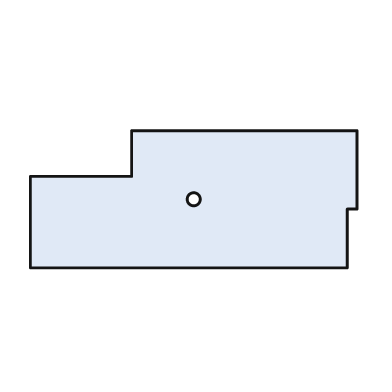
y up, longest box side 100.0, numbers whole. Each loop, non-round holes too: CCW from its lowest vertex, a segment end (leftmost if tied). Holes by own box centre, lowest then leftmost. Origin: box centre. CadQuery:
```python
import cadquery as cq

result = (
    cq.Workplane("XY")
    .moveTo(-50.0, -21.0)
    .lineTo(47.0, -21.0)
    .lineTo(47.0, -3.0)
    .lineTo(50.0, -3.0)
    .lineTo(50.0, 21.0)
    .lineTo(-19.0, 21.0)
    .lineTo(-19.0, 7.0)
    .lineTo(-50.0, 7.0)
    .close()
    .moveTo(0.0, 0.0)
    .circle(2.0)
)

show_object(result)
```